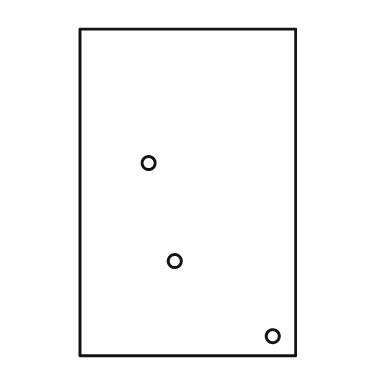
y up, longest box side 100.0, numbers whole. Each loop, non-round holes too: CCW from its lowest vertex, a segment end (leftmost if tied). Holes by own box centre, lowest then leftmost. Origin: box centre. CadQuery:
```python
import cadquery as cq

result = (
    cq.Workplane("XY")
    .moveTo(-33.0, -50.0)
    .lineTo(33.0, -50.0)
    .lineTo(33.0, 50.0)
    .lineTo(-33.0, 50.0)
    .close()
    .moveTo(26.0, -44.0)
    .circle(2.0)
    .moveTo(-4.0, -21.0)
    .circle(2.0)
    .moveTo(-12.0, 9.0)
    .circle(2.0)
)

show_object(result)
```